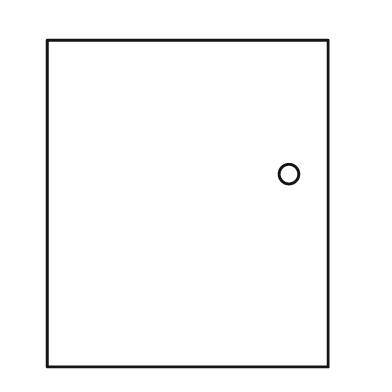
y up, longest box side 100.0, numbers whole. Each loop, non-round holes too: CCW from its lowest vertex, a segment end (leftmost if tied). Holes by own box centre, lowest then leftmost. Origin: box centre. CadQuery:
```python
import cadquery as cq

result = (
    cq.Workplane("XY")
    .moveTo(-43.0, -50.0)
    .lineTo(43.0, -50.0)
    .lineTo(43.0, 50.0)
    .lineTo(-43.0, 50.0)
    .close()
    .moveTo(31.0, 9.0)
    .circle(3.0)
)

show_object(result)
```